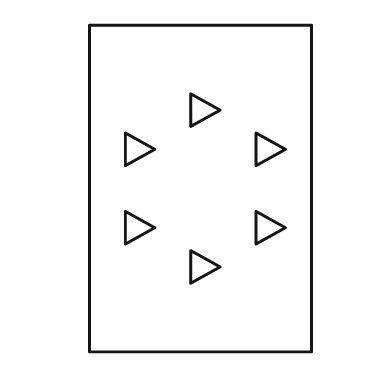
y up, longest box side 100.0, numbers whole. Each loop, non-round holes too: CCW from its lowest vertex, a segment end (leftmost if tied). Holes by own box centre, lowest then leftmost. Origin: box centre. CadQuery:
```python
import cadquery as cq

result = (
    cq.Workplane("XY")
    .moveTo(-34.0, -50.0)
    .lineTo(34.0, -50.0)
    .lineTo(34.0, 50.0)
    .lineTo(-34.0, 50.0)
    .close()
    .moveTo(-3.0, -29.0)
    .lineTo(6.0, -24.0)
    .lineTo(-3.0, -19.0)
    .close()
    .moveTo(-23.0, -17.0)
    .lineTo(-14.0, -12.0)
    .lineTo(-23.0, -7.0)
    .close()
    .moveTo(17.0, -17.0)
    .lineTo(26.0, -12.0)
    .lineTo(17.0, -7.0)
    .close()
    .moveTo(-23.0, 7.0)
    .lineTo(-14.0, 12.0)
    .lineTo(-23.0, 17.0)
    .close()
    .moveTo(17.0, 7.0)
    .lineTo(26.0, 12.0)
    .lineTo(17.0, 17.0)
    .close()
    .moveTo(-3.0, 19.0)
    .lineTo(6.0, 24.0)
    .lineTo(-3.0, 29.0)
    .close()
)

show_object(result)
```